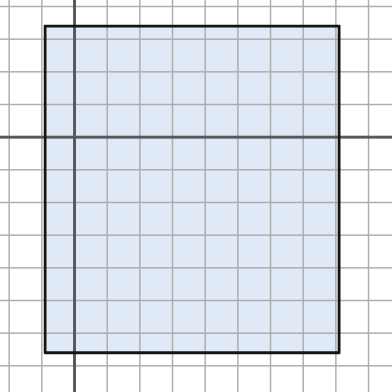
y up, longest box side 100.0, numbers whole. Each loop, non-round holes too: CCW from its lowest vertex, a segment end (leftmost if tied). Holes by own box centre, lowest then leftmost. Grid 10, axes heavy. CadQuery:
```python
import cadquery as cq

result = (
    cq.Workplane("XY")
    .moveTo(-9.0, -66.0)
    .lineTo(81.0, -66.0)
    .lineTo(81.0, 34.0)
    .lineTo(-9.0, 34.0)
    .close()
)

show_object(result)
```